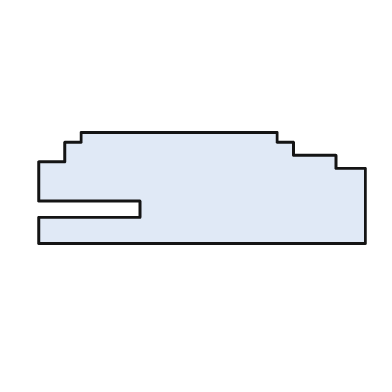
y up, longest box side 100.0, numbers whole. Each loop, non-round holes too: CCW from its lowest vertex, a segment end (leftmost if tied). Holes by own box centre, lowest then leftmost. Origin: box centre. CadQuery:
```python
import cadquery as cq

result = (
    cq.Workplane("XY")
    .moveTo(-50.0, -17.0)
    .lineTo(50.0, -17.0)
    .lineTo(50.0, 6.0)
    .lineTo(41.0, 6.0)
    .lineTo(41.0, 10.0)
    .lineTo(28.0, 10.0)
    .lineTo(28.0, 14.0)
    .lineTo(23.0, 14.0)
    .lineTo(23.0, 17.0)
    .lineTo(-37.0, 17.0)
    .lineTo(-37.0, 14.0)
    .lineTo(-42.0, 14.0)
    .lineTo(-42.0, 8.0)
    .lineTo(-50.0, 8.0)
    .lineTo(-50.0, -4.0)
    .lineTo(-19.0, -4.0)
    .lineTo(-19.0, -9.0)
    .lineTo(-50.0, -9.0)
    .close()
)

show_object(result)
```